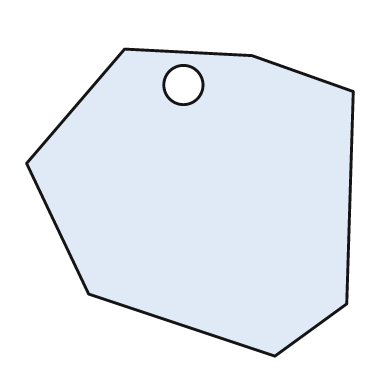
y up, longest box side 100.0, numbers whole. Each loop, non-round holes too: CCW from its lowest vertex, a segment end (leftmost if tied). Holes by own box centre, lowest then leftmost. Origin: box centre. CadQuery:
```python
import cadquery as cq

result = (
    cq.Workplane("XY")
    .moveTo(26.0, -47.0)
    .lineTo(48.0, -31.0)
    .lineTo(50.0, 34.0)
    .lineTo(19.0, 45.0)
    .lineTo(-20.0, 47.0)
    .lineTo(-50.0, 12.0)
    .lineTo(-31.0, -28.0)
    .close()
    .moveTo(-2.0, 36.0)
    .circle(6.0)
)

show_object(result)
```